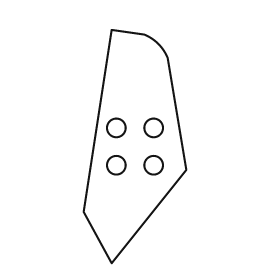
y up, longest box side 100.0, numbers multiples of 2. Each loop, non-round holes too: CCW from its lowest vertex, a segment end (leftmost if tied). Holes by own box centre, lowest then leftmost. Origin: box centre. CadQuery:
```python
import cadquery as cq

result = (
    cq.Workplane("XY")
    .moveTo(-10.0, -50.0)
    .lineTo(22.0, -10.0)
    .lineTo(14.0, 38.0)
    .threePointArc((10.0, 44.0), (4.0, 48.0))
    .lineTo(-10.0, 50.0)
    .lineTo(-22.0, -28.0)
    .close()
    .moveTo(-8.0, -8.0)
    .circle(4.0)
    .moveTo(8.0, -8.0)
    .circle(4.0)
    .moveTo(-8.0, 8.0)
    .circle(4.0)
    .moveTo(8.0, 8.0)
    .circle(4.0)
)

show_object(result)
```